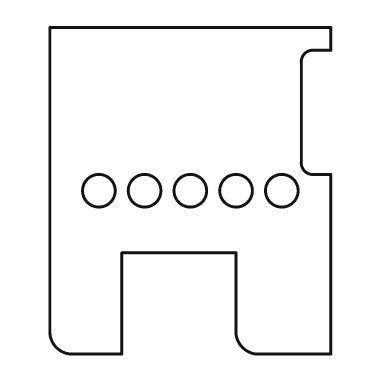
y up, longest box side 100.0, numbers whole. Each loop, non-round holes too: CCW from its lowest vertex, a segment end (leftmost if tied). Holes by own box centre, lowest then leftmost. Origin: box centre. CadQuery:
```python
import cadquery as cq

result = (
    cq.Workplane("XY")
    .moveTo(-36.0, -50.0)
    .lineTo(-21.0, -50.0)
    .lineTo(-21.0, -19.0)
    .lineTo(14.0, -19.0)
    .lineTo(14.0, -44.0)
    .threePointArc((16.0, -48.0), (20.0, -50.0))
    .lineTo(43.0, -50.0)
    .lineTo(43.0, 5.0)
    .lineTo(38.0, 5.0)
    .threePointArc((35.0, 6.0), (34.0, 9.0))
    .lineTo(34.0, 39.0)
    .threePointArc((35.0, 42.0), (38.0, 43.0))
    .lineTo(43.0, 43.0)
    .lineTo(43.0, 50.0)
    .lineTo(-43.0, 50.0)
    .lineTo(-43.0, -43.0)
    .threePointArc((-41.0, -48.0), (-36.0, -50.0))
    .close()
    .moveTo(-28.0, 0.0)
    .circle(5.0)
    .moveTo(-14.0, 0.0)
    .circle(5.0)
    .moveTo(0.0, 0.0)
    .circle(5.0)
    .moveTo(14.0, 0.0)
    .circle(5.0)
    .moveTo(28.0, 0.0)
    .circle(5.0)
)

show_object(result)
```